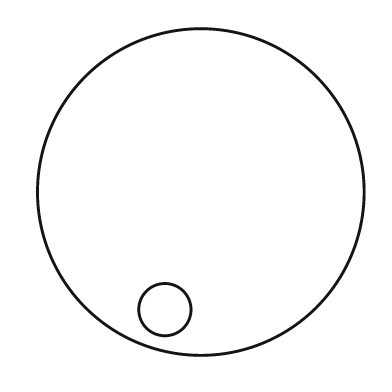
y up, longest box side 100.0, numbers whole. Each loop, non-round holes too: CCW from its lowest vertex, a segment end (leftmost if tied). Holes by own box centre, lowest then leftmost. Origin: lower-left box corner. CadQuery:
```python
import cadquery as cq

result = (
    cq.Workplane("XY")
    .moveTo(50.0, 50.0)
    .circle(50.0)
    .moveTo(39.0, 14.0)
    .circle(8.0)
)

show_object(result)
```